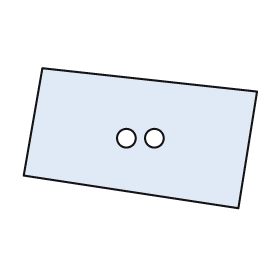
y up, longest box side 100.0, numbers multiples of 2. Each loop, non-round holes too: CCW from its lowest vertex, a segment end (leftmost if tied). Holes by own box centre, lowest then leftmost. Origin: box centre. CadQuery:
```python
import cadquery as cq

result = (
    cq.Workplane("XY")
    .moveTo(42.0, -30.0)
    .lineTo(50.0, 20.0)
    .lineTo(-42.0, 30.0)
    .lineTo(-50.0, -16.0)
    .close()
    .moveTo(-6.0, 0.0)
    .circle(4.0)
    .moveTo(6.0, 0.0)
    .circle(4.0)
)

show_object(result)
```